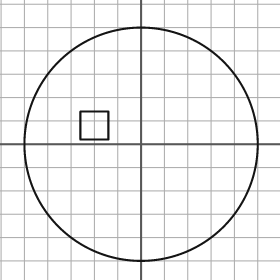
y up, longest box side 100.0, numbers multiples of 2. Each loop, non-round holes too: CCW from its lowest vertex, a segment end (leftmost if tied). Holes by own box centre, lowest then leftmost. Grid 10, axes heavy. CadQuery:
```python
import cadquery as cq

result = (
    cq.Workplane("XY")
    .moveTo(0.0, 0.0)
    .circle(50.0)
    .moveTo(-26.0, 2.0)
    .lineTo(-14.0, 2.0)
    .lineTo(-14.0, 14.0)
    .lineTo(-26.0, 14.0)
    .close()
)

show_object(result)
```